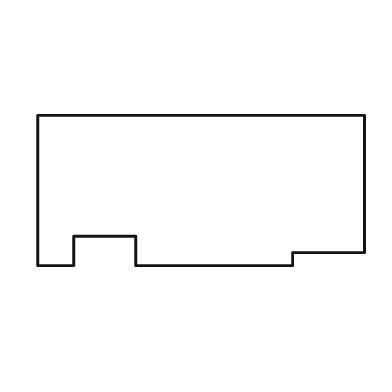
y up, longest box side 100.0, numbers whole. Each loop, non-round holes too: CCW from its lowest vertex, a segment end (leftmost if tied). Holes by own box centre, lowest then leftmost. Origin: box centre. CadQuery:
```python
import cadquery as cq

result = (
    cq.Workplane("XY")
    .moveTo(-50.0, -23.0)
    .lineTo(-39.0, -23.0)
    .lineTo(-39.0, -14.0)
    .lineTo(-20.0, -14.0)
    .lineTo(-20.0, -23.0)
    .lineTo(28.0, -23.0)
    .lineTo(28.0, -19.0)
    .lineTo(50.0, -19.0)
    .lineTo(50.0, 23.0)
    .lineTo(-50.0, 23.0)
    .close()
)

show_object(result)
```